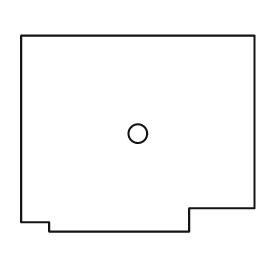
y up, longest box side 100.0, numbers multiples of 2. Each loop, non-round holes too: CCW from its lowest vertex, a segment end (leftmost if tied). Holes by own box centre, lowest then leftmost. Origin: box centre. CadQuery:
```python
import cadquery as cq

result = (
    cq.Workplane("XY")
    .moveTo(-38.0, -42.0)
    .lineTo(22.0, -42.0)
    .lineTo(22.0, -32.0)
    .lineTo(50.0, -32.0)
    .lineTo(50.0, 42.0)
    .lineTo(-50.0, 42.0)
    .lineTo(-50.0, -38.0)
    .lineTo(-38.0, -38.0)
    .close()
    .moveTo(0.0, 0.0)
    .circle(4.0)
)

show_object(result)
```